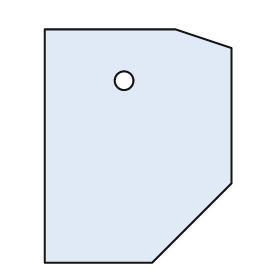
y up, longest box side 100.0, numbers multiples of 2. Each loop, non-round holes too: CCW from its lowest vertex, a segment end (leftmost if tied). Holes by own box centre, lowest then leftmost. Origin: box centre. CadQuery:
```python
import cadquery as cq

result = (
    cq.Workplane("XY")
    .moveTo(-40.0, -50.0)
    .lineTo(6.0, -50.0)
    .lineTo(40.0, -16.0)
    .lineTo(40.0, 42.0)
    .lineTo(16.0, 50.0)
    .lineTo(-40.0, 50.0)
    .close()
    .moveTo(-6.0, 28.0)
    .circle(4.0)
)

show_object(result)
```